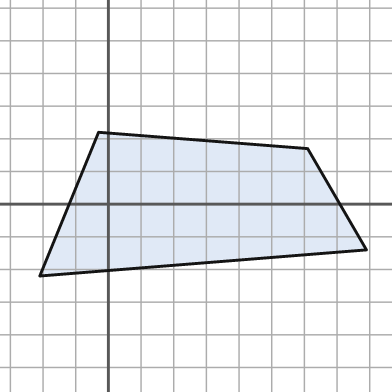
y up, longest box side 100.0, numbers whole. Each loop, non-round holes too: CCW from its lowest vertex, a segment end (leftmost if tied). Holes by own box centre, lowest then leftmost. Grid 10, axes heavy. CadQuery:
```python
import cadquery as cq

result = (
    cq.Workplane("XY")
    .moveTo(-21.0, -22.0)
    .lineTo(79.0, -14.0)
    .lineTo(61.0, 17.0)
    .lineTo(-3.0, 22.0)
    .close()
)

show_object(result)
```